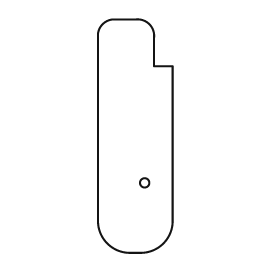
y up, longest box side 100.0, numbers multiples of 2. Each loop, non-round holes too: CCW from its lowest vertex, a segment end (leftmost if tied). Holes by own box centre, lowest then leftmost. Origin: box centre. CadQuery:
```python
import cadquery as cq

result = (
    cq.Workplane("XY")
    .moveTo(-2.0, -50.0)
    .lineTo(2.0, -50.0)
    .threePointArc((12.0, -46.0), (16.0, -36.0))
    .lineTo(16.0, 30.0)
    .lineTo(8.0, 30.0)
    .lineTo(8.0, 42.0)
    .threePointArc((6.0, 48.0), (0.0, 50.0))
    .lineTo(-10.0, 50.0)
    .threePointArc((-14.0, 48.0), (-16.0, 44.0))
    .lineTo(-16.0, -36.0)
    .threePointArc((-12.0, -46.0), (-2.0, -50.0))
    .close()
    .moveTo(4.0, -20.0)
    .circle(2.0)
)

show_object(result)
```